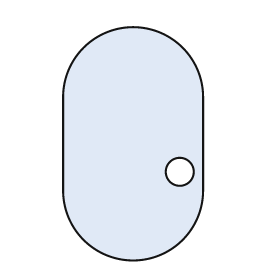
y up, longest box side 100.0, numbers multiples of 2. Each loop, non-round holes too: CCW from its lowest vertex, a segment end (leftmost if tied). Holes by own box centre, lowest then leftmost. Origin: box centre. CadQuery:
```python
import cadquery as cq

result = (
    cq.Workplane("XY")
    .moveTo(-30.0, -20.0)
    .threePointArc((0.0, -50.0), (30.0, -20.0))
    .lineTo(30.0, 20.0)
    .threePointArc((0.0, 50.0), (-30.0, 20.0))
    .close()
    .moveTo(20.0, -12.0)
    .circle(6.0)
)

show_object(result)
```